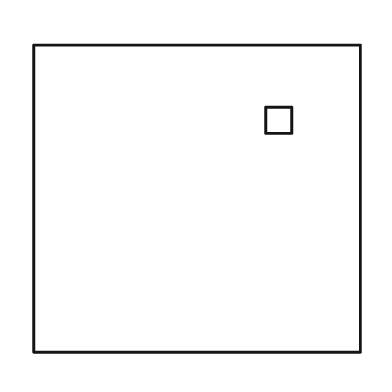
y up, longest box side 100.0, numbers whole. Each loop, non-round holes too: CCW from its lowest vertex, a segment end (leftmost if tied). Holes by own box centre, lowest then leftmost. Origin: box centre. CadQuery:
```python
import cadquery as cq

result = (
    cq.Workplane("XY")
    .moveTo(-50.0, -47.0)
    .lineTo(50.0, -47.0)
    .lineTo(50.0, 47.0)
    .lineTo(-50.0, 47.0)
    .close()
    .moveTo(21.0, 20.0)
    .lineTo(29.0, 20.0)
    .lineTo(29.0, 28.0)
    .lineTo(21.0, 28.0)
    .close()
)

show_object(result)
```